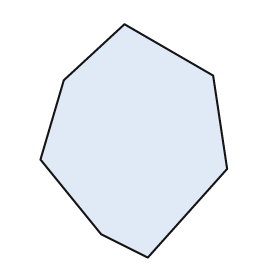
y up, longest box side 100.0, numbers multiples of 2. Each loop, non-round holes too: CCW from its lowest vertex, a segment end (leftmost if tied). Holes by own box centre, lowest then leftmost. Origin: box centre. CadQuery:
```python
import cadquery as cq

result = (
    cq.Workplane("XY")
    .moveTo(6.0, -50.0)
    .lineTo(40.0, -12.0)
    .lineTo(34.0, 28.0)
    .lineTo(-4.0, 50.0)
    .lineTo(-30.0, 26.0)
    .lineTo(-40.0, -8.0)
    .lineTo(-14.0, -40.0)
    .close()
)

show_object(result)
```